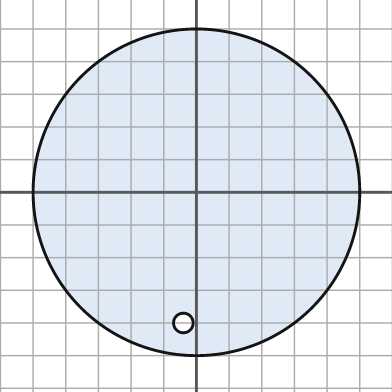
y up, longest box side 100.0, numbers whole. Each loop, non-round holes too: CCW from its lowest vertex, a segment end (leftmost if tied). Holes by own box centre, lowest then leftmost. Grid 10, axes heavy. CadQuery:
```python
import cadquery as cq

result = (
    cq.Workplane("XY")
    .moveTo(0.0, 0.0)
    .circle(50.0)
    .moveTo(-4.0, -40.0)
    .circle(3.0)
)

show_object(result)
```